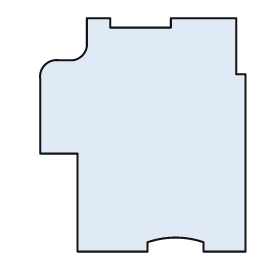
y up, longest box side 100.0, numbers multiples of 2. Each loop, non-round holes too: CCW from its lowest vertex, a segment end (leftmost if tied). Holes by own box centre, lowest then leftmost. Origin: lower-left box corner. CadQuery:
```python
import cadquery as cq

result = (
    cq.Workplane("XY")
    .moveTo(16.0, 0.0)
    .lineTo(46.0, 0.0)
    .lineTo(46.0, 4.0)
    .threePointArc((58.0, 6.0), (70.0, 4.0))
    .lineTo(70.0, 0.0)
    .lineTo(88.0, 0.0)
    .lineTo(88.0, 76.0)
    .lineTo(84.0, 76.0)
    .lineTo(84.0, 100.0)
    .lineTo(56.0, 100.0)
    .lineTo(56.0, 96.0)
    .lineTo(30.0, 96.0)
    .lineTo(30.0, 100.0)
    .lineTo(20.0, 100.0)
    .lineTo(20.0, 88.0)
    .threePointArc((18.0, 84.0), (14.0, 82.0))
    .lineTo(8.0, 82.0)
    .threePointArc((2.0, 80.0), (0.0, 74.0))
    .lineTo(0.0, 42.0)
    .lineTo(16.0, 42.0)
    .close()
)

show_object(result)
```